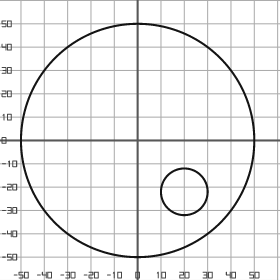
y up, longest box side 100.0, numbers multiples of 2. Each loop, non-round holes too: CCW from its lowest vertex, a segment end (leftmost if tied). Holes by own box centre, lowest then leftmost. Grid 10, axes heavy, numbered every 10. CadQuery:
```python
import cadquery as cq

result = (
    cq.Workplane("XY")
    .moveTo(0.0, 0.0)
    .circle(50.0)
    .moveTo(20.0, -22.0)
    .circle(10.0)
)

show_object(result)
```